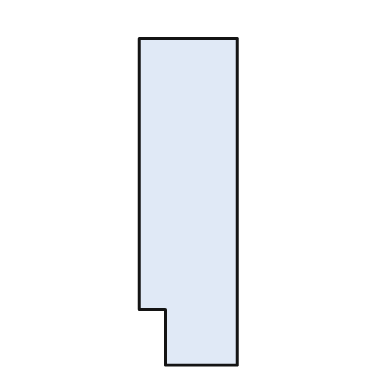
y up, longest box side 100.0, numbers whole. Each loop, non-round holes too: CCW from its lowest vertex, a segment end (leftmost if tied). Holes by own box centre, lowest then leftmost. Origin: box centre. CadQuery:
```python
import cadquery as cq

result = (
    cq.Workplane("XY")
    .moveTo(-7.0, -50.0)
    .lineTo(15.0, -50.0)
    .lineTo(15.0, 50.0)
    .lineTo(-15.0, 50.0)
    .lineTo(-15.0, -33.0)
    .lineTo(-7.0, -33.0)
    .close()
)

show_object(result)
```